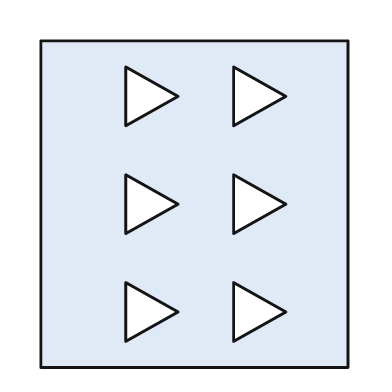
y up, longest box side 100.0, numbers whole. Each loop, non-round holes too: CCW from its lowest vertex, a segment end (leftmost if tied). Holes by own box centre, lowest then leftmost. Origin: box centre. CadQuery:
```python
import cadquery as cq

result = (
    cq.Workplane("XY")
    .moveTo(-47.0, -50.0)
    .lineTo(47.0, -50.0)
    .lineTo(47.0, 50.0)
    .lineTo(-47.0, 50.0)
    .close()
    .moveTo(-21.0, -42.0)
    .lineTo(-5.0, -33.0)
    .lineTo(-21.0, -24.0)
    .close()
    .moveTo(12.0, -42.0)
    .lineTo(28.0, -33.0)
    .lineTo(12.0, -24.0)
    .close()
    .moveTo(-21.0, -9.0)
    .lineTo(-5.0, 0.0)
    .lineTo(-21.0, 9.0)
    .close()
    .moveTo(12.0, -9.0)
    .lineTo(28.0, 0.0)
    .lineTo(12.0, 9.0)
    .close()
    .moveTo(-21.0, 24.0)
    .lineTo(-5.0, 33.0)
    .lineTo(-21.0, 42.0)
    .close()
    .moveTo(12.0, 24.0)
    .lineTo(28.0, 33.0)
    .lineTo(12.0, 42.0)
    .close()
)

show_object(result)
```